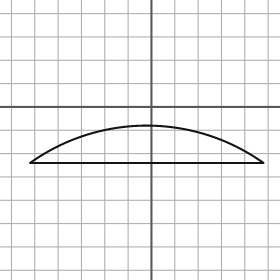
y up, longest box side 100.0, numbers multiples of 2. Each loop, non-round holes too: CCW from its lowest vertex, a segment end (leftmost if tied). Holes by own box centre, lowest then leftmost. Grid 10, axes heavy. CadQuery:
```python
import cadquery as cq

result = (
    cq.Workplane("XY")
    .moveTo(-52.0, -24.0)
    .lineTo(48.0, -24.0)
    .threePointArc((-2.0, -8.0), (-52.0, -24.0))
    .close()
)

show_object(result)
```